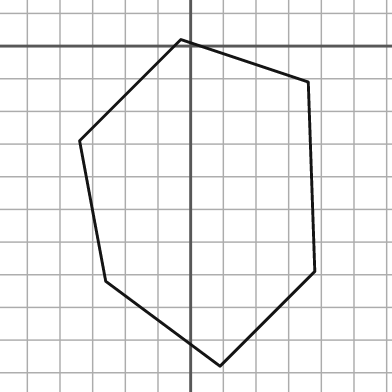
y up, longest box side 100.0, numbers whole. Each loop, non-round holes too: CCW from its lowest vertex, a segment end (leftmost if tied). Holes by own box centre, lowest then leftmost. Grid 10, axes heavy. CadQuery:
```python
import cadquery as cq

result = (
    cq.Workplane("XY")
    .moveTo(9.0, -98.0)
    .lineTo(38.0, -69.0)
    .lineTo(36.0, -11.0)
    .lineTo(-3.0, 2.0)
    .lineTo(-34.0, -29.0)
    .lineTo(-26.0, -72.0)
    .close()
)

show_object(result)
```